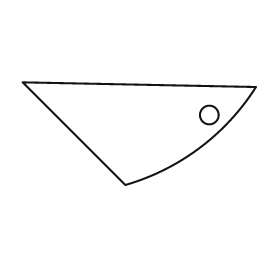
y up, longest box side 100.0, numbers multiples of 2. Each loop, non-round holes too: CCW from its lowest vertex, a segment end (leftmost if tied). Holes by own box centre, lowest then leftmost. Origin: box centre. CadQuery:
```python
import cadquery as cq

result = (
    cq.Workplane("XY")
    .moveTo(-6.0, -22.0)
    .threePointArc((26.0, -6.0), (50.0, 20.0))
    .lineTo(-50.0, 22.0)
    .close()
    .moveTo(30.0, 8.0)
    .circle(4.0)
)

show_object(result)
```